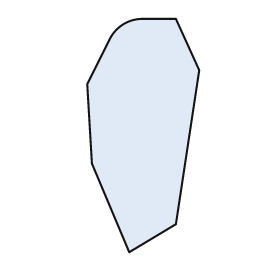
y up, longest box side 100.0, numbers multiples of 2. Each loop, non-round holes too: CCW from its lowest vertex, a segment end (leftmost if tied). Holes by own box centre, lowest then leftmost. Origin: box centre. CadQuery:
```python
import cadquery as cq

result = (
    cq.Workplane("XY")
    .moveTo(-6.0, -50.0)
    .lineTo(14.0, -38.0)
    .lineTo(24.0, 28.0)
    .lineTo(14.0, 50.0)
    .lineTo(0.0, 50.0)
    .threePointArc((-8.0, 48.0), (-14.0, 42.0))
    .lineTo(-24.0, 22.0)
    .lineTo(-22.0, -12.0)
    .close()
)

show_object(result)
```